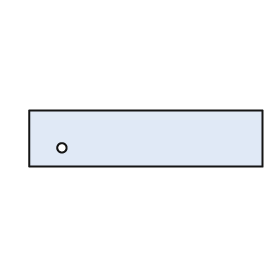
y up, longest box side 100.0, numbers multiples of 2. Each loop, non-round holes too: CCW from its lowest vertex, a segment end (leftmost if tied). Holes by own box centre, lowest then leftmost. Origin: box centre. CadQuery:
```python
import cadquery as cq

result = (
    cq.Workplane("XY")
    .moveTo(-50.0, -12.0)
    .lineTo(50.0, -12.0)
    .lineTo(50.0, 12.0)
    .lineTo(-50.0, 12.0)
    .close()
    .moveTo(-36.0, -4.0)
    .circle(2.0)
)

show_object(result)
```